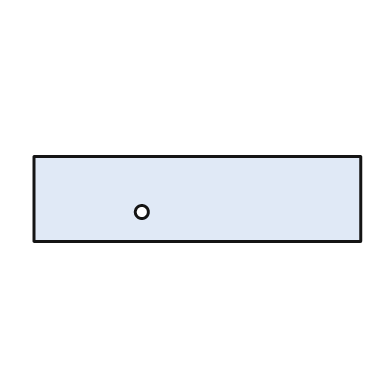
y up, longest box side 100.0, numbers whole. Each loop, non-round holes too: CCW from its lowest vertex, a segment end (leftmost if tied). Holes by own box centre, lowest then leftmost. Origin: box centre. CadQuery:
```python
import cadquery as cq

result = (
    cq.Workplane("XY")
    .moveTo(-50.0, -13.0)
    .lineTo(50.0, -13.0)
    .lineTo(50.0, 13.0)
    .lineTo(-50.0, 13.0)
    .close()
    .moveTo(-17.0, -4.0)
    .circle(2.0)
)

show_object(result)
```